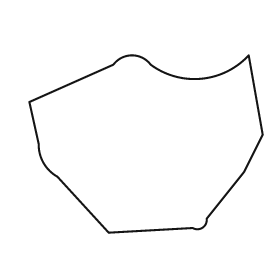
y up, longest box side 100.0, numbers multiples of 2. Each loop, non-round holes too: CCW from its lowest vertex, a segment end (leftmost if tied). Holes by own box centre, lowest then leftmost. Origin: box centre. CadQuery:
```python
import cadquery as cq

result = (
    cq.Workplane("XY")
    .moveTo(-16.0, -38.0)
    .lineTo(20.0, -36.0)
    .threePointArc((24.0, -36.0), (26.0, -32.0))
    .lineTo(42.0, -12.0)
    .lineTo(50.0, 4.0)
    .lineTo(44.0, 38.0)
    .threePointArc((24.0, 28.0), (2.0, 34.0))
    .threePointArc((-6.0, 38.0), (-14.0, 34.0))
    .lineTo(-50.0, 18.0)
    .lineTo(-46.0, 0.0)
    .threePointArc((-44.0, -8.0), (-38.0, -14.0))
    .close()
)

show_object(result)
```